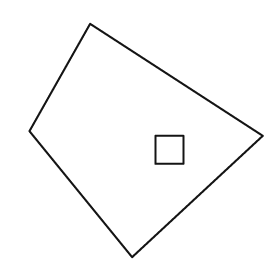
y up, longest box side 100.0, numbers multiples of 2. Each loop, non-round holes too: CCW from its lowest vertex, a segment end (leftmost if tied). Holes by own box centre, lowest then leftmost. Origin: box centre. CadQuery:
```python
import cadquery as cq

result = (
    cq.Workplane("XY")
    .moveTo(-6.0, -50.0)
    .lineTo(50.0, 2.0)
    .lineTo(-24.0, 50.0)
    .lineTo(-50.0, 4.0)
    .close()
    .moveTo(4.0, -10.0)
    .lineTo(16.0, -10.0)
    .lineTo(16.0, 2.0)
    .lineTo(4.0, 2.0)
    .close()
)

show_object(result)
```